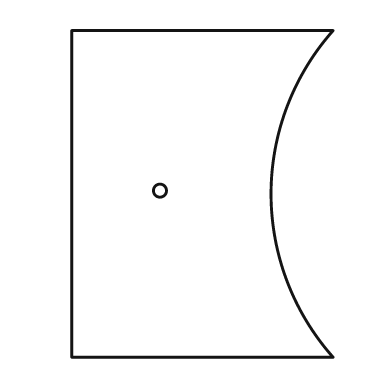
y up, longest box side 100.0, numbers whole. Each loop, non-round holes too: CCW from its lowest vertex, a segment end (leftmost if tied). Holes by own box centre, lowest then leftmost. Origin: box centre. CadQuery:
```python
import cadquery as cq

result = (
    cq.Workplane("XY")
    .moveTo(-40.0, -50.0)
    .lineTo(40.0, -50.0)
    .threePointArc((21.0, 0.0), (40.0, 50.0))
    .lineTo(-40.0, 50.0)
    .close()
    .moveTo(-13.0, 1.0)
    .circle(2.0)
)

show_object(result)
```